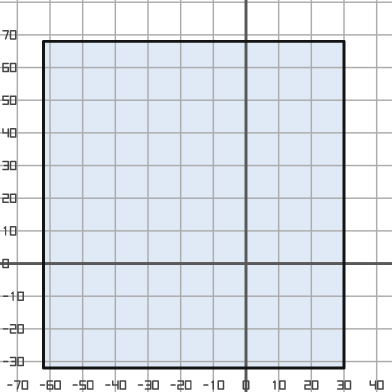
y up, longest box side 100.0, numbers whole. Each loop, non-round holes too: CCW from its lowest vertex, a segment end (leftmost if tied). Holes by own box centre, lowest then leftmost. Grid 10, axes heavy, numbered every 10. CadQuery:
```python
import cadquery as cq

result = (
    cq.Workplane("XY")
    .moveTo(-62.0, -32.0)
    .lineTo(30.0, -32.0)
    .lineTo(30.0, 68.0)
    .lineTo(-62.0, 68.0)
    .close()
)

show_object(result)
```